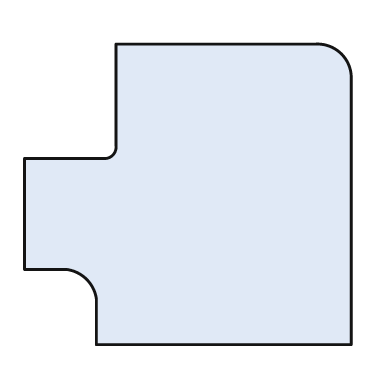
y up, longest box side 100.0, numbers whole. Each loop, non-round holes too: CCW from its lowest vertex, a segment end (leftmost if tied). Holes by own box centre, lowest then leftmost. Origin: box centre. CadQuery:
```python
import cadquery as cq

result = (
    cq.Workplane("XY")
    .moveTo(-28.0, -46.0)
    .lineTo(50.0, -46.0)
    .lineTo(50.0, 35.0)
    .threePointArc((47.0, 43.0), (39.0, 46.0))
    .lineTo(-22.0, 46.0)
    .lineTo(-22.0, 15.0)
    .threePointArc((-23.0, 12.0), (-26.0, 11.0))
    .lineTo(-50.0, 11.0)
    .lineTo(-50.0, -23.0)
    .lineTo(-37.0, -23.0)
    .threePointArc((-31.0, -26.0), (-28.0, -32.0))
    .close()
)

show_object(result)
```